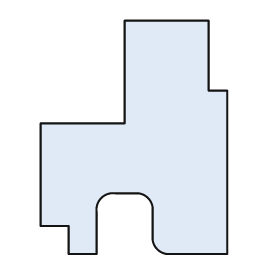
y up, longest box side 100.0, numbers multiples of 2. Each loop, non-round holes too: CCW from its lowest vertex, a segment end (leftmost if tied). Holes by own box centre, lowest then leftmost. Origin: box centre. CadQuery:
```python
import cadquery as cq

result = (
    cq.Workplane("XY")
    .moveTo(-28.0, -50.0)
    .lineTo(-16.0, -50.0)
    .lineTo(-16.0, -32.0)
    .threePointArc((-14.0, -26.0), (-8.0, -24.0))
    .lineTo(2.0, -24.0)
    .threePointArc((6.0, -26.0), (8.0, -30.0))
    .lineTo(8.0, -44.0)
    .threePointArc((10.0, -48.0), (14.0, -50.0))
    .lineTo(40.0, -50.0)
    .lineTo(40.0, 20.0)
    .lineTo(32.0, 20.0)
    .lineTo(32.0, 50.0)
    .lineTo(-4.0, 50.0)
    .lineTo(-4.0, 6.0)
    .lineTo(-40.0, 6.0)
    .lineTo(-40.0, -38.0)
    .lineTo(-28.0, -38.0)
    .close()
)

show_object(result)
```